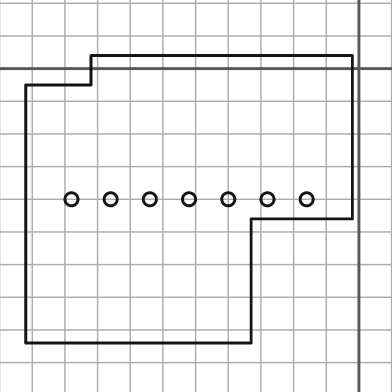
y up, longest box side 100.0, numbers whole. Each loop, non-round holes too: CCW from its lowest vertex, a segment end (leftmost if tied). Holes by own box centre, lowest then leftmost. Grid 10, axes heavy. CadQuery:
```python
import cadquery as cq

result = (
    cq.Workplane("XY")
    .moveTo(-102.0, -84.0)
    .lineTo(-33.0, -84.0)
    .lineTo(-33.0, -46.0)
    .lineTo(-2.0, -46.0)
    .lineTo(-2.0, 4.0)
    .lineTo(-82.0, 4.0)
    .lineTo(-82.0, -5.0)
    .lineTo(-102.0, -5.0)
    .close()
    .moveTo(-88.0, -40.0)
    .circle(2.0)
    .moveTo(-76.0, -40.0)
    .circle(2.0)
    .moveTo(-64.0, -40.0)
    .circle(2.0)
    .moveTo(-52.0, -40.0)
    .circle(2.0)
    .moveTo(-40.0, -40.0)
    .circle(2.0)
    .moveTo(-28.0, -40.0)
    .circle(2.0)
    .moveTo(-16.0, -40.0)
    .circle(2.0)
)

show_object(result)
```